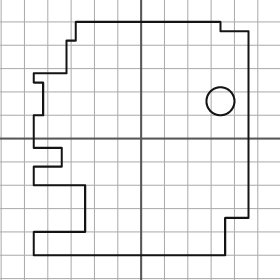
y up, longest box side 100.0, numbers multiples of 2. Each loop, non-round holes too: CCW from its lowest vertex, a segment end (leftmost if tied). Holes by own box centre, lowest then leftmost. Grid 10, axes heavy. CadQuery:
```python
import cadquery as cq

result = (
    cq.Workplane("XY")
    .moveTo(-46.0, -50.0)
    .lineTo(36.0, -50.0)
    .lineTo(36.0, -34.0)
    .lineTo(46.0, -34.0)
    .lineTo(46.0, 46.0)
    .lineTo(34.0, 46.0)
    .lineTo(34.0, 50.0)
    .lineTo(-28.0, 50.0)
    .lineTo(-28.0, 42.0)
    .lineTo(-32.0, 42.0)
    .lineTo(-32.0, 28.0)
    .lineTo(-46.0, 28.0)
    .lineTo(-46.0, 24.0)
    .lineTo(-42.0, 24.0)
    .lineTo(-42.0, 10.0)
    .lineTo(-46.0, 10.0)
    .lineTo(-46.0, -4.0)
    .lineTo(-34.0, -4.0)
    .lineTo(-34.0, -12.0)
    .lineTo(-46.0, -12.0)
    .lineTo(-46.0, -20.0)
    .lineTo(-24.0, -20.0)
    .lineTo(-24.0, -40.0)
    .lineTo(-46.0, -40.0)
    .close()
    .moveTo(34.0, 16.0)
    .circle(6.0)
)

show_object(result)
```